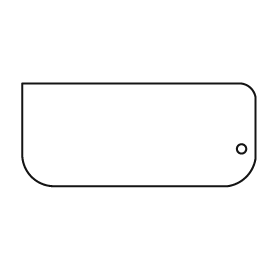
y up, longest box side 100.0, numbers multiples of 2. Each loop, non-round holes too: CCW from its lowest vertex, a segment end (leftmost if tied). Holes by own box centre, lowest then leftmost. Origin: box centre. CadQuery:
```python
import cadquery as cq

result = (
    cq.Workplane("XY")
    .moveTo(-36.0, -22.0)
    .lineTo(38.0, -22.0)
    .threePointArc((46.0, -18.0), (50.0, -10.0))
    .lineTo(50.0, 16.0)
    .threePointArc((48.0, 20.0), (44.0, 22.0))
    .lineTo(-50.0, 22.0)
    .lineTo(-50.0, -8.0)
    .threePointArc((-46.0, -18.0), (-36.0, -22.0))
    .close()
    .moveTo(44.0, -6.0)
    .circle(2.0)
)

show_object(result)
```